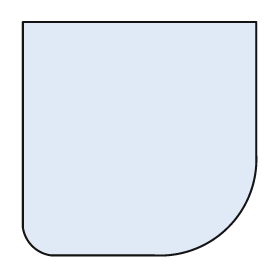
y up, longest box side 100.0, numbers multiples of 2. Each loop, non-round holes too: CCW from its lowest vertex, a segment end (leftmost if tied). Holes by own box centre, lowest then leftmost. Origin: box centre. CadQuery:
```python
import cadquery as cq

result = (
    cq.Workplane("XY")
    .moveTo(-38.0, -50.0)
    .lineTo(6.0, -50.0)
    .threePointArc((38.0, -38.0), (50.0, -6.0))
    .lineTo(50.0, 50.0)
    .lineTo(-50.0, 50.0)
    .lineTo(-50.0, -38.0)
    .threePointArc((-46.0, -46.0), (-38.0, -50.0))
    .close()
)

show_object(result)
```